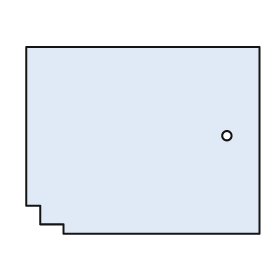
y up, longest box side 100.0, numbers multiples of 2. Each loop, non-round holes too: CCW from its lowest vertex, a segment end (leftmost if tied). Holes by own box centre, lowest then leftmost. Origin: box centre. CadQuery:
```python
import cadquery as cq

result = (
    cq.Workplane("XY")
    .moveTo(-34.0, -40.0)
    .lineTo(50.0, -40.0)
    .lineTo(50.0, 40.0)
    .lineTo(-50.0, 40.0)
    .lineTo(-50.0, -28.0)
    .lineTo(-44.0, -28.0)
    .lineTo(-44.0, -36.0)
    .lineTo(-34.0, -36.0)
    .close()
    .moveTo(36.0, 2.0)
    .circle(2.0)
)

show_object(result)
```